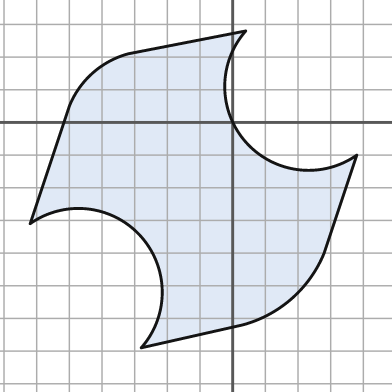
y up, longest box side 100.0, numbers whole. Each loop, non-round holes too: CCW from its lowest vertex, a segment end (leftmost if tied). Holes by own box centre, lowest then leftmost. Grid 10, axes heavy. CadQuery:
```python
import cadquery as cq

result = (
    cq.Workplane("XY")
    .moveTo(-28.0, -69.0)
    .lineTo(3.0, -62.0)
    .threePointArc((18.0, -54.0), (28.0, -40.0))
    .lineTo(38.0, -10.0)
    .threePointArc((4.0, -6.0), (4.0, 28.0))
    .lineTo(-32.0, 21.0)
    .threePointArc((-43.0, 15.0), (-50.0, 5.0))
    .lineTo(-62.0, -31.0)
    .threePointArc((-28.0, -35.0), (-28.0, -69.0))
    .close()
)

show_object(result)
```